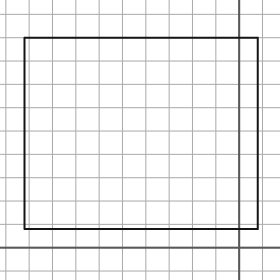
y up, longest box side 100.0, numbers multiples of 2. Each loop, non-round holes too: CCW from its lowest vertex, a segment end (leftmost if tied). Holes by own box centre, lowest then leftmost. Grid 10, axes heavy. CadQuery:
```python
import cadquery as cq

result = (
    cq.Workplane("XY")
    .moveTo(-92.0, 8.0)
    .lineTo(8.0, 8.0)
    .lineTo(8.0, 90.0)
    .lineTo(-92.0, 90.0)
    .close()
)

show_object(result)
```